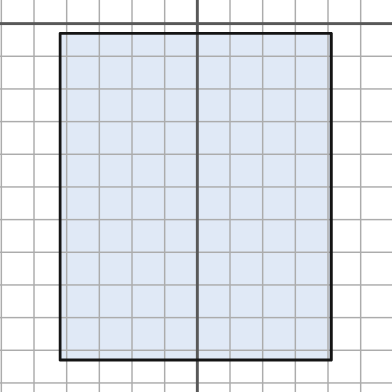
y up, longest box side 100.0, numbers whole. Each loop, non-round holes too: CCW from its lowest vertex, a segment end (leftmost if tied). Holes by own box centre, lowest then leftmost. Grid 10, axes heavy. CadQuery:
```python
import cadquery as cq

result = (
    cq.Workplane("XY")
    .moveTo(-42.0, -103.0)
    .lineTo(41.0, -103.0)
    .lineTo(41.0, -3.0)
    .lineTo(-42.0, -3.0)
    .close()
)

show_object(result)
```